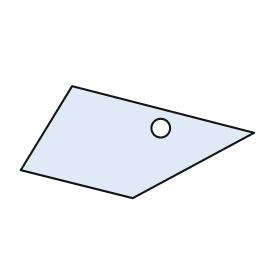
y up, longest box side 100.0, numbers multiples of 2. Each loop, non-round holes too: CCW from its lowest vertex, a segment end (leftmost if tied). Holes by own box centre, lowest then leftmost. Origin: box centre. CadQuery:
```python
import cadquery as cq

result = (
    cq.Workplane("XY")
    .moveTo(-2.0, -24.0)
    .lineTo(50.0, 4.0)
    .lineTo(-28.0, 24.0)
    .lineTo(-50.0, -12.0)
    .close()
    .moveTo(10.0, 6.0)
    .circle(4.0)
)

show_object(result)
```